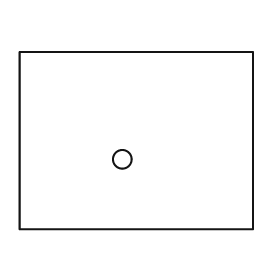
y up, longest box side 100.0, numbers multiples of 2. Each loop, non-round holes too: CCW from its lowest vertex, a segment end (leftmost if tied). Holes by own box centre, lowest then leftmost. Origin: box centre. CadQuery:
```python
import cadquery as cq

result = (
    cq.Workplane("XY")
    .moveTo(-50.0, -38.0)
    .lineTo(50.0, -38.0)
    .lineTo(50.0, 38.0)
    .lineTo(-50.0, 38.0)
    .close()
    .moveTo(-6.0, -8.0)
    .circle(4.0)
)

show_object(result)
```